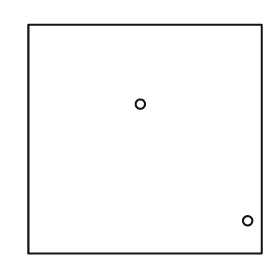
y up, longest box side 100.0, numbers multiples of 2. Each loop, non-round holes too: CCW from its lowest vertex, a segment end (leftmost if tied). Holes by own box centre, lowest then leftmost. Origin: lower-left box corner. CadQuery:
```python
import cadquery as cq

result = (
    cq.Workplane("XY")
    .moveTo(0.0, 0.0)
    .lineTo(100.0, 0.0)
    .lineTo(100.0, 98.0)
    .lineTo(0.0, 98.0)
    .close()
    .moveTo(94.0, 14.0)
    .circle(2.0)
    .moveTo(48.0, 64.0)
    .circle(2.0)
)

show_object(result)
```